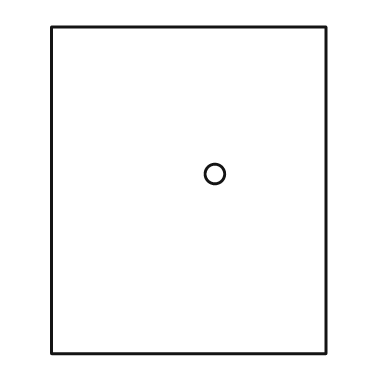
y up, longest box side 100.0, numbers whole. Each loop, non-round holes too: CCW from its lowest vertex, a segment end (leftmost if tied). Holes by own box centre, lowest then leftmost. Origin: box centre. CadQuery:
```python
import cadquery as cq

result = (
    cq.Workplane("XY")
    .moveTo(-42.0, -50.0)
    .lineTo(42.0, -50.0)
    .lineTo(42.0, 50.0)
    .lineTo(-42.0, 50.0)
    .close()
    .moveTo(8.0, 5.0)
    .circle(3.0)
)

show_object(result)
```